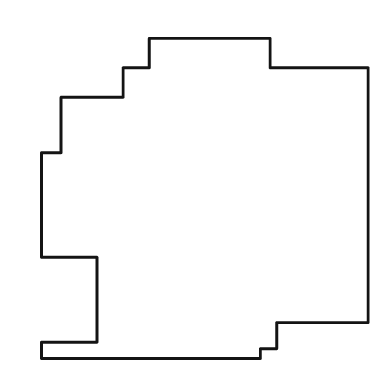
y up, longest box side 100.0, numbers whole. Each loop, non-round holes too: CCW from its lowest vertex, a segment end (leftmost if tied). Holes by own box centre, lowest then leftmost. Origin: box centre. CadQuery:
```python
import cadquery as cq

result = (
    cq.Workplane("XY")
    .moveTo(-50.0, -49.0)
    .lineTo(17.0, -49.0)
    .lineTo(17.0, -46.0)
    .lineTo(22.0, -46.0)
    .lineTo(22.0, -38.0)
    .lineTo(50.0, -38.0)
    .lineTo(50.0, 40.0)
    .lineTo(20.0, 40.0)
    .lineTo(20.0, 49.0)
    .lineTo(-17.0, 49.0)
    .lineTo(-17.0, 40.0)
    .lineTo(-25.0, 40.0)
    .lineTo(-25.0, 31.0)
    .lineTo(-44.0, 31.0)
    .lineTo(-44.0, 14.0)
    .lineTo(-50.0, 14.0)
    .lineTo(-50.0, -18.0)
    .lineTo(-33.0, -18.0)
    .lineTo(-33.0, -44.0)
    .lineTo(-50.0, -44.0)
    .close()
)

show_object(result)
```